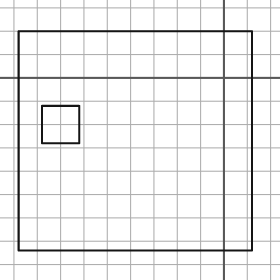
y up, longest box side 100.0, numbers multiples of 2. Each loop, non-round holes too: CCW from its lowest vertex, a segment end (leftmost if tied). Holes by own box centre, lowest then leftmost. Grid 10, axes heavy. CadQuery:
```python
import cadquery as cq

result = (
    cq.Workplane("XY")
    .moveTo(-88.0, -74.0)
    .lineTo(12.0, -74.0)
    .lineTo(12.0, 20.0)
    .lineTo(-88.0, 20.0)
    .close()
    .moveTo(-78.0, -28.0)
    .lineTo(-62.0, -28.0)
    .lineTo(-62.0, -12.0)
    .lineTo(-78.0, -12.0)
    .close()
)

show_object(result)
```